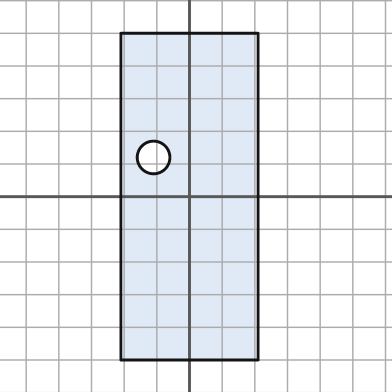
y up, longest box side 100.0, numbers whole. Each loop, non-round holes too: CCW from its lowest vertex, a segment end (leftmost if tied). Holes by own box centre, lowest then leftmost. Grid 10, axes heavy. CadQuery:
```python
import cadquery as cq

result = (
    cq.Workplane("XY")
    .moveTo(-21.0, -50.0)
    .lineTo(21.0, -50.0)
    .lineTo(21.0, 50.0)
    .lineTo(-21.0, 50.0)
    .close()
    .moveTo(-11.0, 12.0)
    .circle(5.0)
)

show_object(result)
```